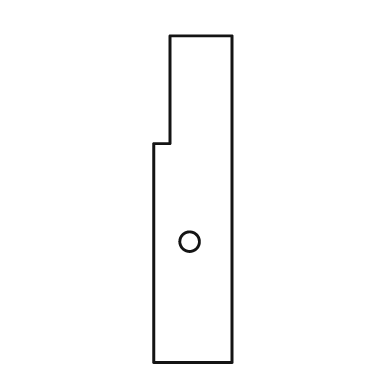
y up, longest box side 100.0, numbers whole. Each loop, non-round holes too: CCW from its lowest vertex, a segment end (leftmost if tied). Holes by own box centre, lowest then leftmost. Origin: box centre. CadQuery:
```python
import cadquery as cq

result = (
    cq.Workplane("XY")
    .moveTo(-12.0, -50.0)
    .lineTo(12.0, -50.0)
    .lineTo(12.0, 50.0)
    .lineTo(-7.0, 50.0)
    .lineTo(-7.0, 17.0)
    .lineTo(-12.0, 17.0)
    .close()
    .moveTo(-1.0, -13.0)
    .circle(3.0)
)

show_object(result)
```